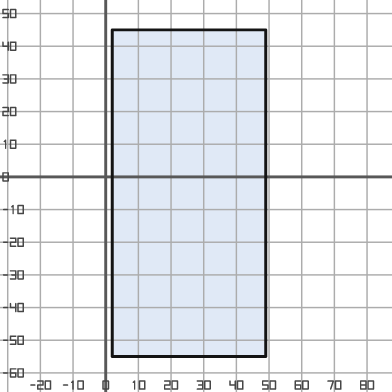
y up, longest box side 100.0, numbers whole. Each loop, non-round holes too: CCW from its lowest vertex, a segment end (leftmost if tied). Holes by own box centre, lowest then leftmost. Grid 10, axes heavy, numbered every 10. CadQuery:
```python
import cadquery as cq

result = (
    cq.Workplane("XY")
    .moveTo(2.0, -55.0)
    .lineTo(49.0, -55.0)
    .lineTo(49.0, 45.0)
    .lineTo(2.0, 45.0)
    .close()
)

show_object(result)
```